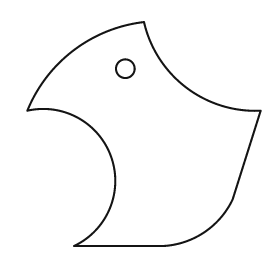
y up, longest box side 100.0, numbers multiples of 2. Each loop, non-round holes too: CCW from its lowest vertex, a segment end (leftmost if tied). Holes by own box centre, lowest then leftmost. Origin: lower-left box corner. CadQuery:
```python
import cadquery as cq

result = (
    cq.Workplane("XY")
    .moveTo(20.0, 0.0)
    .lineTo(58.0, 0.0)
    .threePointArc((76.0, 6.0), (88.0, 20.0))
    .lineTo(100.0, 58.0)
    .threePointArc((68.0, 68.0), (50.0, 96.0))
    .threePointArc((20.0, 84.0), (0.0, 58.0))
    .threePointArc((36.0, 38.0), (20.0, 0.0))
    .close()
    .moveTo(42.0, 76.0)
    .circle(4.0)
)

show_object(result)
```